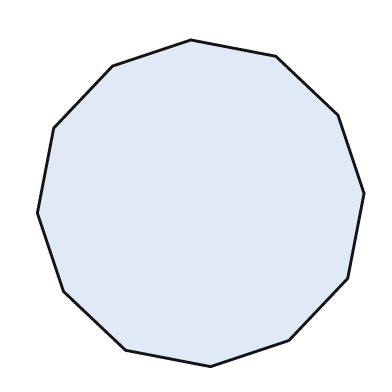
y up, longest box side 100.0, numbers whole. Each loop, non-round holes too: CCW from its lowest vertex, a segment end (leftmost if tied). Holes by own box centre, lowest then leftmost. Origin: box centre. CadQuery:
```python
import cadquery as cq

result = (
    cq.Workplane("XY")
    .moveTo(3.0, -50.0)
    .lineTo(27.0, -42.0)
    .lineTo(45.0, -23.0)
    .lineTo(50.0, 3.0)
    .lineTo(42.0, 27.0)
    .lineTo(23.0, 45.0)
    .lineTo(-3.0, 50.0)
    .lineTo(-27.0, 42.0)
    .lineTo(-45.0, 23.0)
    .lineTo(-50.0, -3.0)
    .lineTo(-42.0, -27.0)
    .lineTo(-23.0, -45.0)
    .close()
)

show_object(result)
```